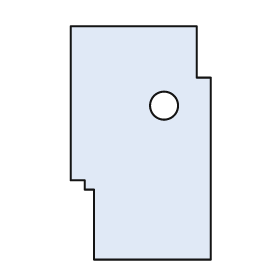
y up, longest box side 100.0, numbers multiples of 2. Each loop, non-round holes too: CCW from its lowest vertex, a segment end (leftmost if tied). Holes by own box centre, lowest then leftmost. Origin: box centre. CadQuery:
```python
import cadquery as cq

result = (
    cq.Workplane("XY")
    .moveTo(-20.0, -50.0)
    .lineTo(30.0, -50.0)
    .lineTo(30.0, 28.0)
    .lineTo(24.0, 28.0)
    .lineTo(24.0, 50.0)
    .lineTo(-30.0, 50.0)
    .lineTo(-30.0, -16.0)
    .lineTo(-24.0, -16.0)
    .lineTo(-24.0, -20.0)
    .lineTo(-20.0, -20.0)
    .close()
    .moveTo(10.0, 16.0)
    .circle(6.0)
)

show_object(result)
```